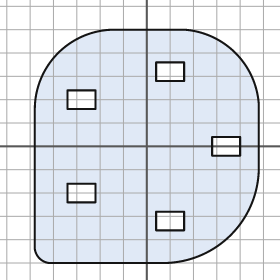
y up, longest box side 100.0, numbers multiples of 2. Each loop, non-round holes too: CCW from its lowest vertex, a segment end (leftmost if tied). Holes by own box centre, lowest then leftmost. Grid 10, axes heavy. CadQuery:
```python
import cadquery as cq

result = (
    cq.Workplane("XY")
    .moveTo(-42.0, -50.0)
    .lineTo(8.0, -50.0)
    .threePointArc((36.0, -38.0), (48.0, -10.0))
    .lineTo(48.0, 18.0)
    .threePointArc((38.0, 40.0), (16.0, 50.0))
    .lineTo(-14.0, 50.0)
    .threePointArc((-38.0, 40.0), (-48.0, 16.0))
    .lineTo(-48.0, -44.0)
    .threePointArc((-46.0, -48.0), (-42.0, -50.0))
    .close()
    .moveTo(4.0, -36.0)
    .lineTo(16.0, -36.0)
    .lineTo(16.0, -28.0)
    .lineTo(4.0, -28.0)
    .close()
    .moveTo(-34.0, -24.0)
    .lineTo(-22.0, -24.0)
    .lineTo(-22.0, -16.0)
    .lineTo(-34.0, -16.0)
    .close()
    .moveTo(28.0, -4.0)
    .lineTo(40.0, -4.0)
    .lineTo(40.0, 4.0)
    .lineTo(28.0, 4.0)
    .close()
    .moveTo(-34.0, 16.0)
    .lineTo(-22.0, 16.0)
    .lineTo(-22.0, 24.0)
    .lineTo(-34.0, 24.0)
    .close()
    .moveTo(4.0, 28.0)
    .lineTo(16.0, 28.0)
    .lineTo(16.0, 36.0)
    .lineTo(4.0, 36.0)
    .close()
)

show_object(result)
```